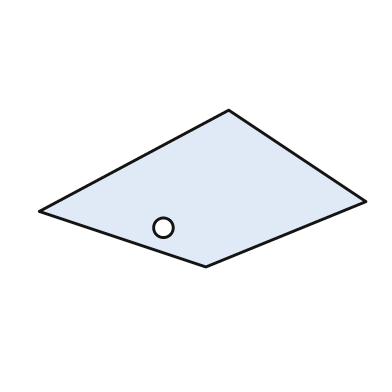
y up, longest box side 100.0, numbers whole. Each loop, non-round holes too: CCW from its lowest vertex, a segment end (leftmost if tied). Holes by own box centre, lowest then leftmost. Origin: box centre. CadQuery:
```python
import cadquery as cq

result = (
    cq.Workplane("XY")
    .moveTo(1.0, -24.0)
    .lineTo(50.0, -4.0)
    .lineTo(8.0, 24.0)
    .lineTo(-50.0, -7.0)
    .close()
    .moveTo(-12.0, -12.0)
    .circle(3.0)
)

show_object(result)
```